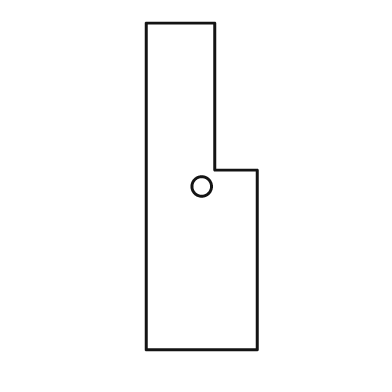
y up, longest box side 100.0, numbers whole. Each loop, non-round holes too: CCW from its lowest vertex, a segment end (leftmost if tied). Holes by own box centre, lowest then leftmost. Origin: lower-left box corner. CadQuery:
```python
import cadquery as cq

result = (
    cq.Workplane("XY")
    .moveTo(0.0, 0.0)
    .lineTo(34.0, 0.0)
    .lineTo(34.0, 55.0)
    .lineTo(21.0, 55.0)
    .lineTo(21.0, 100.0)
    .lineTo(0.0, 100.0)
    .close()
    .moveTo(17.0, 50.0)
    .circle(3.0)
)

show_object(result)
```